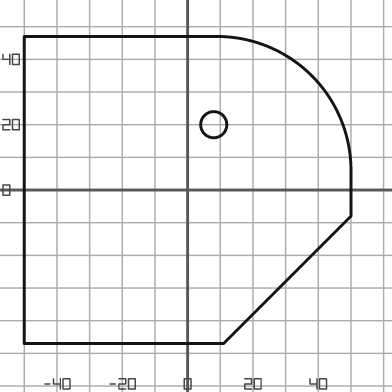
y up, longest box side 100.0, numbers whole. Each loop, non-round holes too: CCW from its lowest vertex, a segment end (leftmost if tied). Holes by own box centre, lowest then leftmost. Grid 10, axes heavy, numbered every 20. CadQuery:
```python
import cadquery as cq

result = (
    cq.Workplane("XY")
    .moveTo(-50.0, -47.0)
    .lineTo(11.0, -47.0)
    .lineTo(50.0, -8.0)
    .lineTo(50.0, 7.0)
    .threePointArc((38.0, 35.0), (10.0, 47.0))
    .lineTo(-50.0, 47.0)
    .close()
    .moveTo(8.0, 20.0)
    .circle(4.0)
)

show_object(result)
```